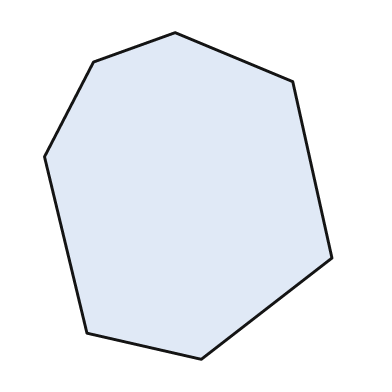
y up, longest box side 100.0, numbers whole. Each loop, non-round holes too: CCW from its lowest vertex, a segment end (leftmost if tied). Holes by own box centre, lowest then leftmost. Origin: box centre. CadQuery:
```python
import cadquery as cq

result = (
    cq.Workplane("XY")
    .moveTo(4.0, -50.0)
    .lineTo(44.0, -19.0)
    .lineTo(32.0, 35.0)
    .lineTo(-4.0, 50.0)
    .lineTo(-29.0, 41.0)
    .lineTo(-44.0, 12.0)
    .lineTo(-31.0, -42.0)
    .close()
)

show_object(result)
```